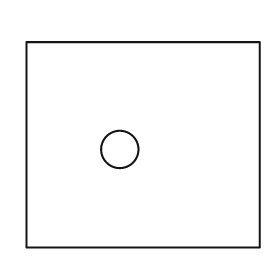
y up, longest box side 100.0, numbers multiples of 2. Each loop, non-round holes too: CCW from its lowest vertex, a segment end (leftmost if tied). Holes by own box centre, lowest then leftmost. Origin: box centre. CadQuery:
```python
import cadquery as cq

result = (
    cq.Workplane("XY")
    .moveTo(-50.0, -44.0)
    .lineTo(50.0, -44.0)
    .lineTo(50.0, 44.0)
    .lineTo(-50.0, 44.0)
    .close()
    .moveTo(-10.0, -2.0)
    .circle(8.0)
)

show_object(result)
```